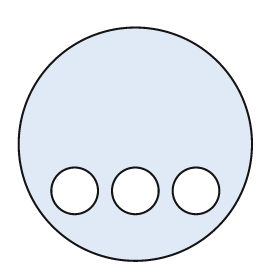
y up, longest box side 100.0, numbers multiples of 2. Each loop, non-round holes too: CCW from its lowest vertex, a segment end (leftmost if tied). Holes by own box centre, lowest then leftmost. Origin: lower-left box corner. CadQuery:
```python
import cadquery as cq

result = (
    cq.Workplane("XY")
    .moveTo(50.0, 50.0)
    .circle(50.0)
    .moveTo(24.0, 30.0)
    .circle(10.0)
    .moveTo(50.0, 30.0)
    .circle(10.0)
    .moveTo(76.0, 30.0)
    .circle(10.0)
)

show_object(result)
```